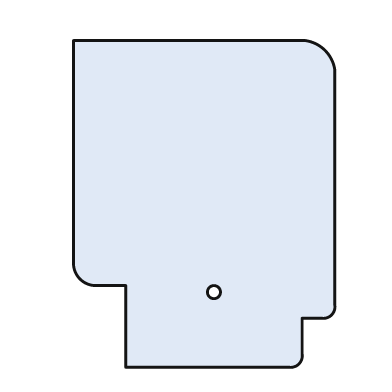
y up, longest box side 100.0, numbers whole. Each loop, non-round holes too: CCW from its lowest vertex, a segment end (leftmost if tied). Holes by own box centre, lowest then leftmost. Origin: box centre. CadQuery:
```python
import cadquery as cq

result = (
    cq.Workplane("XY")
    .moveTo(-24.0, -50.0)
    .lineTo(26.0, -50.0)
    .threePointArc((29.0, -49.0), (30.0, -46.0))
    .lineTo(30.0, -35.0)
    .lineTo(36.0, -35.0)
    .threePointArc((39.0, -34.0), (40.0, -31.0))
    .lineTo(40.0, 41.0)
    .threePointArc((37.0, 47.0), (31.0, 50.0))
    .lineTo(-40.0, 50.0)
    .lineTo(-40.0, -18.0)
    .threePointArc((-38.0, -23.0), (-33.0, -25.0))
    .lineTo(-24.0, -25.0)
    .close()
    .moveTo(3.0, -27.0)
    .circle(2.0)
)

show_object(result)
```